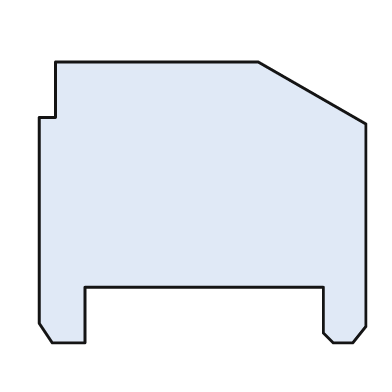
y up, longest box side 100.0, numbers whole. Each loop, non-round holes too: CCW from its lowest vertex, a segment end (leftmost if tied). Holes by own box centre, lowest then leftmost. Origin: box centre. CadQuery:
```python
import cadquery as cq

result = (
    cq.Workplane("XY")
    .moveTo(-46.0, -43.0)
    .lineTo(-36.0, -43.0)
    .lineTo(-36.0, -26.0)
    .lineTo(37.0, -26.0)
    .lineTo(37.0, -40.0)
    .lineTo(40.0, -43.0)
    .lineTo(46.0, -43.0)
    .lineTo(50.0, -38.0)
    .lineTo(50.0, 24.0)
    .lineTo(17.0, 43.0)
    .lineTo(-45.0, 43.0)
    .lineTo(-45.0, 26.0)
    .lineTo(-50.0, 26.0)
    .lineTo(-50.0, -37.0)
    .close()
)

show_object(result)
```